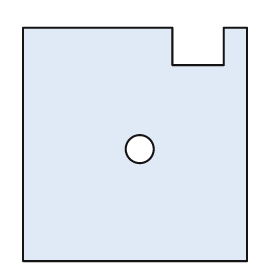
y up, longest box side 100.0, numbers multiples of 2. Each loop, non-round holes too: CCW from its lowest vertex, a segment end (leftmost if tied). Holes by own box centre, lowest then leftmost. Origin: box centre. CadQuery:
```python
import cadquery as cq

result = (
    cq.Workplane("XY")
    .moveTo(-48.0, -50.0)
    .lineTo(48.0, -50.0)
    .lineTo(48.0, 50.0)
    .lineTo(38.0, 50.0)
    .lineTo(38.0, 34.0)
    .lineTo(16.0, 34.0)
    .lineTo(16.0, 50.0)
    .lineTo(-48.0, 50.0)
    .close()
    .moveTo(2.0, -2.0)
    .circle(6.0)
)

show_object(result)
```